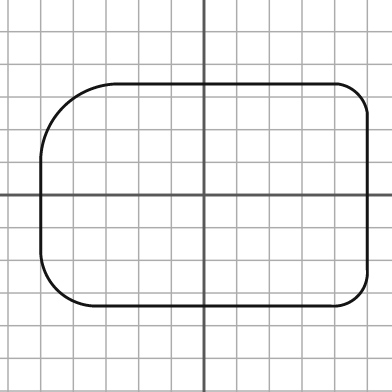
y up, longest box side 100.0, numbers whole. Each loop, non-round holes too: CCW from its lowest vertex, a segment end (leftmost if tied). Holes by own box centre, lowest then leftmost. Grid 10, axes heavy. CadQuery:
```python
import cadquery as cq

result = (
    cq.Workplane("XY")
    .moveTo(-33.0, -34.0)
    .lineTo(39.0, -34.0)
    .threePointArc((47.0, -31.0), (50.0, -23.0))
    .lineTo(50.0, 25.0)
    .threePointArc((47.0, 31.0), (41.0, 34.0))
    .lineTo(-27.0, 34.0)
    .threePointArc((-43.0, 27.0), (-50.0, 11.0))
    .lineTo(-50.0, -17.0)
    .threePointArc((-45.0, -29.0), (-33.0, -34.0))
    .close()
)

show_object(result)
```